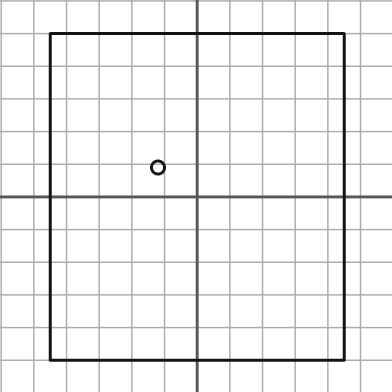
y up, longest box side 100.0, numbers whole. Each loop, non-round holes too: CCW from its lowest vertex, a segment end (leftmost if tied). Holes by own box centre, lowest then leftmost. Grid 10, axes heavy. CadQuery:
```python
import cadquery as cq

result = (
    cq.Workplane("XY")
    .moveTo(-45.0, -50.0)
    .lineTo(45.0, -50.0)
    .lineTo(45.0, 50.0)
    .lineTo(-45.0, 50.0)
    .close()
    .moveTo(-12.0, 9.0)
    .circle(2.0)
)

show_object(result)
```